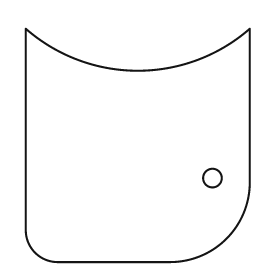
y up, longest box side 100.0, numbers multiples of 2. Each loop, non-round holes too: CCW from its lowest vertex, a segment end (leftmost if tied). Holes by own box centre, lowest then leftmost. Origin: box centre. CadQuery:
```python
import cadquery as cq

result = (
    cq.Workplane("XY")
    .moveTo(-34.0, -50.0)
    .lineTo(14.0, -50.0)
    .threePointArc((38.0, -40.0), (48.0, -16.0))
    .lineTo(48.0, 50.0)
    .threePointArc((0.0, 32.0), (-48.0, 50.0))
    .lineTo(-48.0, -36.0)
    .threePointArc((-44.0, -46.0), (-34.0, -50.0))
    .close()
    .moveTo(32.0, -14.0)
    .circle(4.0)
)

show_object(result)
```